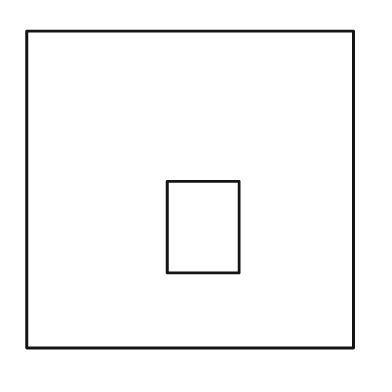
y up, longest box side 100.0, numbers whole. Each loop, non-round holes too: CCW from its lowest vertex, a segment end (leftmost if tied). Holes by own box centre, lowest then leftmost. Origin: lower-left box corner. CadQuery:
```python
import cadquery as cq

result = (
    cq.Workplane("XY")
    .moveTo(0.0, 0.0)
    .lineTo(100.0, 0.0)
    .lineTo(100.0, 97.0)
    .lineTo(0.0, 97.0)
    .close()
    .moveTo(43.0, 23.0)
    .lineTo(65.0, 23.0)
    .lineTo(65.0, 51.0)
    .lineTo(43.0, 51.0)
    .close()
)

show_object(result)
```